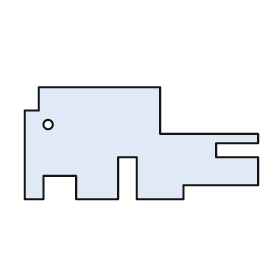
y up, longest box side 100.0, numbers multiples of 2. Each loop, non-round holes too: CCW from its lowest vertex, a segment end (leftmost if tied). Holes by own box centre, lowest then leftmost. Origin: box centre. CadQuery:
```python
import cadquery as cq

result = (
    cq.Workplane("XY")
    .moveTo(-50.0, -24.0)
    .lineTo(-42.0, -24.0)
    .lineTo(-42.0, -14.0)
    .lineTo(-28.0, -14.0)
    .lineTo(-28.0, -24.0)
    .lineTo(-10.0, -24.0)
    .lineTo(-10.0, -6.0)
    .lineTo(-2.0, -6.0)
    .lineTo(-2.0, -24.0)
    .lineTo(18.0, -24.0)
    .lineTo(18.0, -18.0)
    .lineTo(50.0, -18.0)
    .lineTo(50.0, -6.0)
    .lineTo(32.0, -6.0)
    .lineTo(32.0, 0.0)
    .lineTo(50.0, 0.0)
    .lineTo(50.0, 4.0)
    .lineTo(8.0, 4.0)
    .lineTo(8.0, 24.0)
    .lineTo(-44.0, 24.0)
    .lineTo(-44.0, 14.0)
    .lineTo(-50.0, 14.0)
    .close()
    .moveTo(-40.0, 8.0)
    .circle(2.0)
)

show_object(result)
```